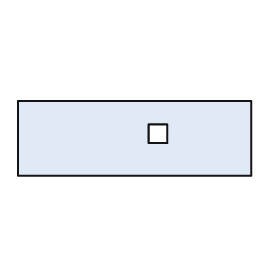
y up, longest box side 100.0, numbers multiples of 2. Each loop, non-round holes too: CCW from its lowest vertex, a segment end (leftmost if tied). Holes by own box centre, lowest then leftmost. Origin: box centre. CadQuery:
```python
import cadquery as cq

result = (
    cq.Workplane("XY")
    .moveTo(-50.0, -16.0)
    .lineTo(50.0, -16.0)
    .lineTo(50.0, 16.0)
    .lineTo(-50.0, 16.0)
    .close()
    .moveTo(6.0, -2.0)
    .lineTo(14.0, -2.0)
    .lineTo(14.0, 6.0)
    .lineTo(6.0, 6.0)
    .close()
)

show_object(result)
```